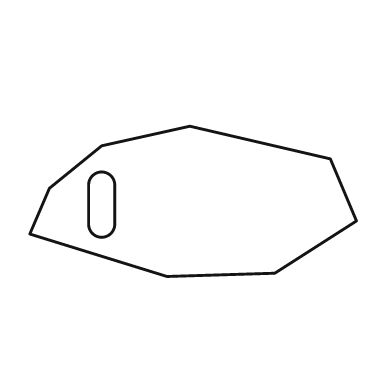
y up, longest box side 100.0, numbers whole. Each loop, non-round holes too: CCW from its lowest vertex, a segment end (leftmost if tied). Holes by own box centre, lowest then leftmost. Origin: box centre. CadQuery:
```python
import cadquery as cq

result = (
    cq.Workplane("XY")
    .moveTo(-8.0, -23.0)
    .lineTo(25.0, -22.0)
    .lineTo(50.0, -6.0)
    .lineTo(42.0, 13.0)
    .lineTo(-1.0, 23.0)
    .lineTo(-28.0, 17.0)
    .lineTo(-44.0, 4.0)
    .lineTo(-50.0, -10.0)
    .close()
    .moveTo(-32.0, -7.0)
    .threePointArc((-28.0, -11.0), (-24.0, -7.0))
    .lineTo(-24.0, 5.0)
    .threePointArc((-28.0, 9.0), (-32.0, 5.0))
    .close()
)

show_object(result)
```